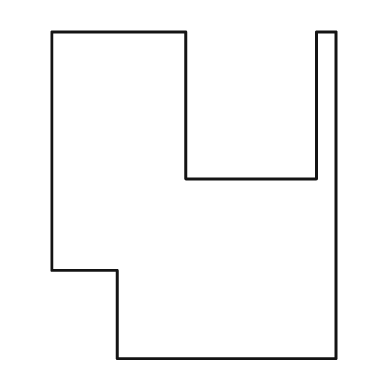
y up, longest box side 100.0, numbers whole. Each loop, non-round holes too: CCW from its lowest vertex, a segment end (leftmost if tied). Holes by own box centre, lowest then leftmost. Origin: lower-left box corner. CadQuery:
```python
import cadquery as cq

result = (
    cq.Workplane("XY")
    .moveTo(20.0, 0.0)
    .lineTo(87.0, 0.0)
    .lineTo(87.0, 100.0)
    .lineTo(81.0, 100.0)
    .lineTo(81.0, 55.0)
    .lineTo(41.0, 55.0)
    .lineTo(41.0, 100.0)
    .lineTo(0.0, 100.0)
    .lineTo(0.0, 27.0)
    .lineTo(20.0, 27.0)
    .close()
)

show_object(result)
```